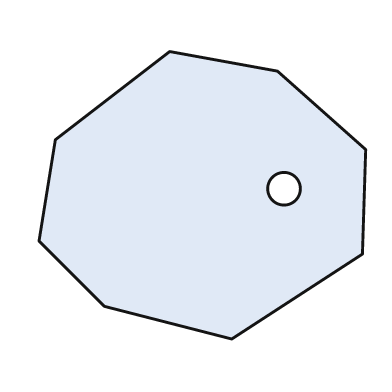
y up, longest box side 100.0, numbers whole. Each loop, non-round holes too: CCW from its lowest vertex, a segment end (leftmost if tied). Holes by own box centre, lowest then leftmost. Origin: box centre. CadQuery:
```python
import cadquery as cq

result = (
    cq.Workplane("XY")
    .moveTo(9.0, -44.0)
    .lineTo(49.0, -18.0)
    .lineTo(50.0, 14.0)
    .lineTo(23.0, 38.0)
    .lineTo(-10.0, 44.0)
    .lineTo(-45.0, 17.0)
    .lineTo(-50.0, -14.0)
    .lineTo(-30.0, -34.0)
    .close()
    .moveTo(25.0, 2.0)
    .circle(5.0)
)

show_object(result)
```